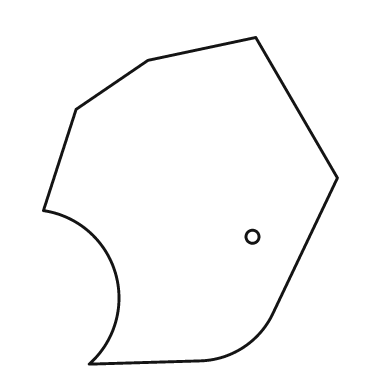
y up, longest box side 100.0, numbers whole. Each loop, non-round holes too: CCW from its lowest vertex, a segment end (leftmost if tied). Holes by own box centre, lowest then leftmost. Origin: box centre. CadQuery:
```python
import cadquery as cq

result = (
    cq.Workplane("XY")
    .moveTo(-31.0, -50.0)
    .lineTo(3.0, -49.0)
    .threePointArc((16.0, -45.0), (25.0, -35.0))
    .lineTo(45.0, 7.0)
    .lineTo(20.0, 50.0)
    .lineTo(-13.0, 43.0)
    .lineTo(-35.0, 28.0)
    .lineTo(-45.0, -3.0)
    .threePointArc((-23.0, -22.0), (-31.0, -50.0))
    .close()
    .moveTo(19.0, -11.0)
    .circle(2.0)
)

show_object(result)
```